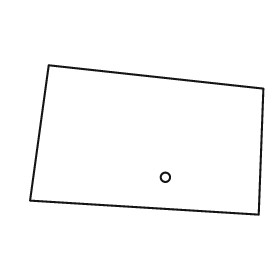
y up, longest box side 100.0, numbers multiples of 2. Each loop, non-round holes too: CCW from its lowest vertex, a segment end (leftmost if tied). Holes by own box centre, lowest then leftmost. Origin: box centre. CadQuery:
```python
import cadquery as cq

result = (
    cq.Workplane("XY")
    .moveTo(48.0, -32.0)
    .lineTo(50.0, 22.0)
    .lineTo(-42.0, 32.0)
    .lineTo(-50.0, -26.0)
    .close()
    .moveTo(8.0, -16.0)
    .circle(2.0)
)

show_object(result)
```